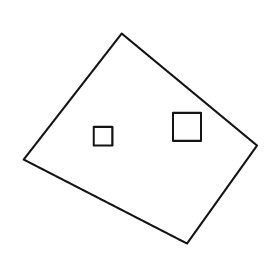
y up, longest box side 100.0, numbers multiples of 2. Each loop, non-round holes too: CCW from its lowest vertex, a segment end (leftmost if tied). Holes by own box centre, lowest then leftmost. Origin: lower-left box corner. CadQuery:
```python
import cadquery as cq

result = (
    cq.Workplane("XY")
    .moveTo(70.0, 0.0)
    .lineTo(100.0, 42.0)
    .lineTo(42.0, 90.0)
    .lineTo(0.0, 36.0)
    .close()
    .moveTo(30.0, 42.0)
    .lineTo(38.0, 42.0)
    .lineTo(38.0, 50.0)
    .lineTo(30.0, 50.0)
    .close()
    .moveTo(64.0, 44.0)
    .lineTo(76.0, 44.0)
    .lineTo(76.0, 56.0)
    .lineTo(64.0, 56.0)
    .close()
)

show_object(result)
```